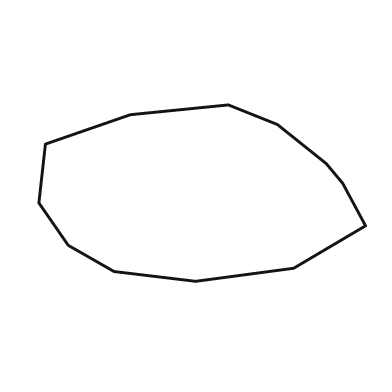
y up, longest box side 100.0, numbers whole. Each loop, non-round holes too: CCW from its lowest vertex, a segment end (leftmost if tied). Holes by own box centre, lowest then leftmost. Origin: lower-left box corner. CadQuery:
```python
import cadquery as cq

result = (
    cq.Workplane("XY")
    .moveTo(48.0, 0.0)
    .lineTo(78.0, 4.0)
    .lineTo(100.0, 17.0)
    .lineTo(93.0, 30.0)
    .lineTo(88.0, 36.0)
    .lineTo(73.0, 48.0)
    .lineTo(58.0, 54.0)
    .lineTo(28.0, 51.0)
    .lineTo(2.0, 42.0)
    .lineTo(0.0, 24.0)
    .lineTo(9.0, 11.0)
    .lineTo(23.0, 3.0)
    .close()
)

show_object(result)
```